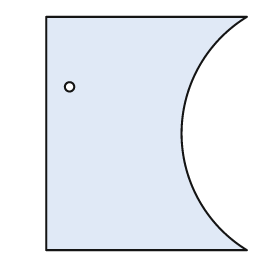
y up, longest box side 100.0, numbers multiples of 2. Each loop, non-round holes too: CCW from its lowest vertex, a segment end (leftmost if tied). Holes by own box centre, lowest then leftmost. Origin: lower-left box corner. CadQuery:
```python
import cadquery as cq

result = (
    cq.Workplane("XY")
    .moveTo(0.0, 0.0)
    .lineTo(86.0, 0.0)
    .threePointArc((58.0, 50.0), (86.0, 100.0))
    .lineTo(0.0, 100.0)
    .close()
    .moveTo(10.0, 70.0)
    .circle(2.0)
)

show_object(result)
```